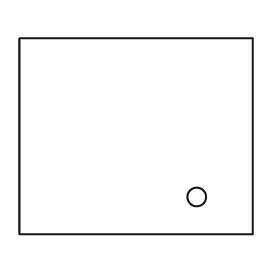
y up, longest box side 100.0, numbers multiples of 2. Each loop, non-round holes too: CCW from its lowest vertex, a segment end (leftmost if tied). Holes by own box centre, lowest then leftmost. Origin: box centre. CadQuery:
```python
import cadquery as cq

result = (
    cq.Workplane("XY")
    .moveTo(-50.0, -42.0)
    .lineTo(50.0, -42.0)
    .lineTo(50.0, 42.0)
    .lineTo(-50.0, 42.0)
    .close()
    .moveTo(26.0, -26.0)
    .circle(4.0)
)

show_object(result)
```